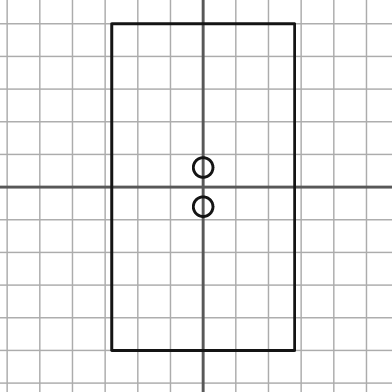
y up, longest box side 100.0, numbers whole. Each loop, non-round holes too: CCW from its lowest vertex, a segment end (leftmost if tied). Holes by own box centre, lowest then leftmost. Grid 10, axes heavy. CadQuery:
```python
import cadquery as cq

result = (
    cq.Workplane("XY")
    .moveTo(-28.0, -50.0)
    .lineTo(28.0, -50.0)
    .lineTo(28.0, 50.0)
    .lineTo(-28.0, 50.0)
    .close()
    .moveTo(0.0, -6.0)
    .circle(3.0)
    .moveTo(0.0, 6.0)
    .circle(3.0)
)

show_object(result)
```